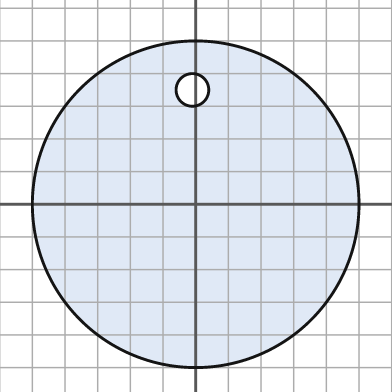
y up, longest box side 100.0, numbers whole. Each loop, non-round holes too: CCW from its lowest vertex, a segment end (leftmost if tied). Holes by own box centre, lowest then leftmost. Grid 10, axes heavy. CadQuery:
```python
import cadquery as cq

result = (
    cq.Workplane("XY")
    .moveTo(0.0, 0.0)
    .circle(50.0)
    .moveTo(-1.0, 35.0)
    .circle(5.0)
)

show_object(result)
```